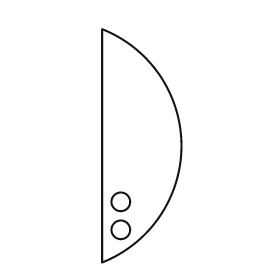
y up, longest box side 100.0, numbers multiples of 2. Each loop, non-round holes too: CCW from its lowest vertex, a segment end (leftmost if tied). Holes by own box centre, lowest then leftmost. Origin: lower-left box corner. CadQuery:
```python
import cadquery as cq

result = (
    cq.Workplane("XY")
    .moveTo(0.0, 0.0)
    .threePointArc((34.0, 50.0), (0.0, 100.0))
    .close()
    .moveTo(8.0, 14.0)
    .circle(4.0)
    .moveTo(8.0, 26.0)
    .circle(4.0)
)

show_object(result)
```